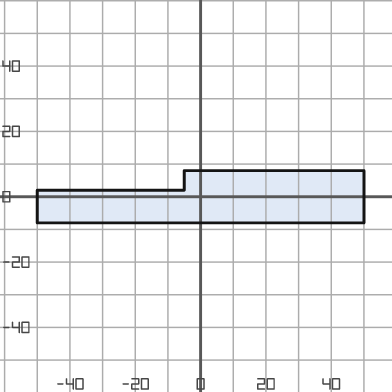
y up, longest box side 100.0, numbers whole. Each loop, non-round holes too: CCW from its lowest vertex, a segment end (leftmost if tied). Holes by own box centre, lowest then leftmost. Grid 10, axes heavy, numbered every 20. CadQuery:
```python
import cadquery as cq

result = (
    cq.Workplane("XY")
    .moveTo(-50.0, -8.0)
    .lineTo(50.0, -8.0)
    .lineTo(50.0, 8.0)
    .lineTo(-5.0, 8.0)
    .lineTo(-5.0, 2.0)
    .lineTo(-50.0, 2.0)
    .close()
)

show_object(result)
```